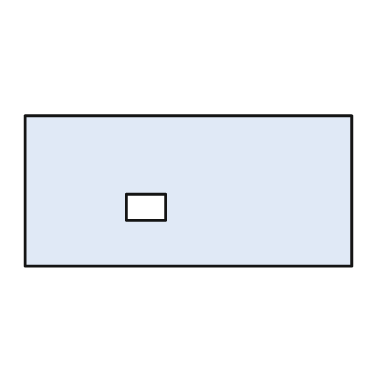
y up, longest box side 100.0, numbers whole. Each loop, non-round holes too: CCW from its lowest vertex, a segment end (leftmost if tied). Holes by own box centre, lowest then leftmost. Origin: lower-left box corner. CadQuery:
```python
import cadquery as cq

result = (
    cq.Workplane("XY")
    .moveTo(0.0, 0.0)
    .lineTo(100.0, 0.0)
    .lineTo(100.0, 46.0)
    .lineTo(0.0, 46.0)
    .close()
    .moveTo(31.0, 14.0)
    .lineTo(43.0, 14.0)
    .lineTo(43.0, 22.0)
    .lineTo(31.0, 22.0)
    .close()
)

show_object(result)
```